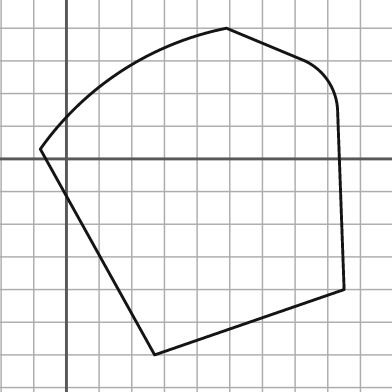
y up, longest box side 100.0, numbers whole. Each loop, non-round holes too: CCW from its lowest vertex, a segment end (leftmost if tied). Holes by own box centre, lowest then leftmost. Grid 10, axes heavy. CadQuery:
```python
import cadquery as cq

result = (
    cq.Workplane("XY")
    .moveTo(27.0, -60.0)
    .lineTo(85.0, -40.0)
    .lineTo(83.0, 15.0)
    .threePointArc((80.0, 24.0), (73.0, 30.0))
    .lineTo(49.0, 40.0)
    .threePointArc((17.0, 27.0), (-8.0, 3.0))
    .close()
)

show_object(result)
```